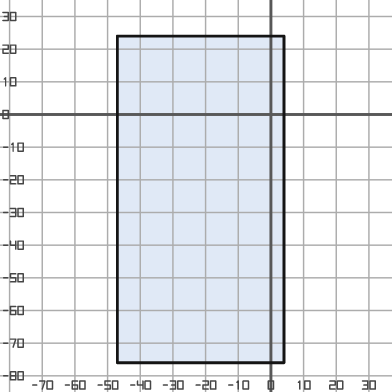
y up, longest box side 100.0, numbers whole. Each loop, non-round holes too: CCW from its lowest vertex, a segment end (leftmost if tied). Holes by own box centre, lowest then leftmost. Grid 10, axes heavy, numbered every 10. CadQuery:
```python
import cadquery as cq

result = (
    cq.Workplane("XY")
    .moveTo(-47.0, -76.0)
    .lineTo(4.0, -76.0)
    .lineTo(4.0, 24.0)
    .lineTo(-47.0, 24.0)
    .close()
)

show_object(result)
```